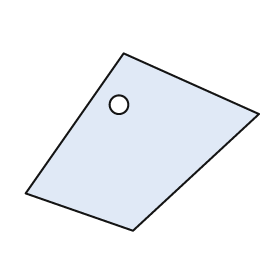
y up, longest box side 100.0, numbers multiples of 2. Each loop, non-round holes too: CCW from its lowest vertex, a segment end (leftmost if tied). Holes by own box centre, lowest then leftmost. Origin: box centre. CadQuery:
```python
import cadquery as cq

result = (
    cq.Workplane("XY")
    .moveTo(-4.0, -38.0)
    .lineTo(50.0, 12.0)
    .lineTo(-8.0, 38.0)
    .lineTo(-50.0, -22.0)
    .close()
    .moveTo(-10.0, 16.0)
    .circle(4.0)
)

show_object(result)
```